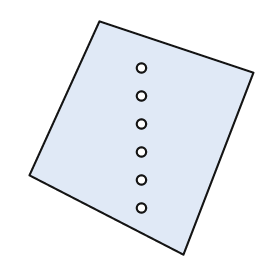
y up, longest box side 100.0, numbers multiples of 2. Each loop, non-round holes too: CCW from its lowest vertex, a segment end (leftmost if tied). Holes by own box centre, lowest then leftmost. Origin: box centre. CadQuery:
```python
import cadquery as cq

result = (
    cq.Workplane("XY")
    .moveTo(18.0, -50.0)
    .lineTo(48.0, 28.0)
    .lineTo(-18.0, 50.0)
    .lineTo(-48.0, -16.0)
    .close()
    .moveTo(0.0, -30.0)
    .circle(2.0)
    .moveTo(0.0, -18.0)
    .circle(2.0)
    .moveTo(0.0, -6.0)
    .circle(2.0)
    .moveTo(0.0, 6.0)
    .circle(2.0)
    .moveTo(0.0, 18.0)
    .circle(2.0)
    .moveTo(0.0, 30.0)
    .circle(2.0)
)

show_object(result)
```